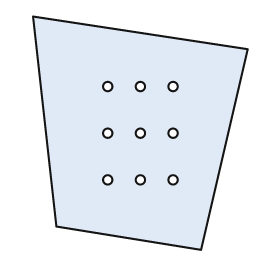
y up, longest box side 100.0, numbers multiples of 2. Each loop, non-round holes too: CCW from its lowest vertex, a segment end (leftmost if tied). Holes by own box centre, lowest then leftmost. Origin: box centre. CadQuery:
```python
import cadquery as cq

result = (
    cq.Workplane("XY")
    .moveTo(26.0, -50.0)
    .lineTo(46.0, 36.0)
    .lineTo(-46.0, 50.0)
    .lineTo(-36.0, -40.0)
    .close()
    .moveTo(-14.0, -20.0)
    .circle(2.0)
    .moveTo(0.0, -20.0)
    .circle(2.0)
    .moveTo(14.0, -20.0)
    .circle(2.0)
    .moveTo(-14.0, 0.0)
    .circle(2.0)
    .moveTo(0.0, 0.0)
    .circle(2.0)
    .moveTo(14.0, 0.0)
    .circle(2.0)
    .moveTo(-14.0, 20.0)
    .circle(2.0)
    .moveTo(0.0, 20.0)
    .circle(2.0)
    .moveTo(14.0, 20.0)
    .circle(2.0)
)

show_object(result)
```